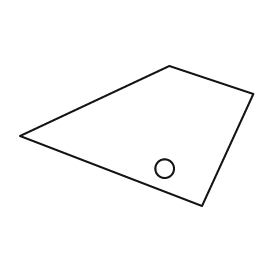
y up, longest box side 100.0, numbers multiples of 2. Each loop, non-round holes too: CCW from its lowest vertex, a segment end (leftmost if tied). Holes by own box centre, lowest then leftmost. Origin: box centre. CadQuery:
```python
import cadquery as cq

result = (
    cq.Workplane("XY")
    .moveTo(28.0, -30.0)
    .lineTo(50.0, 18.0)
    .lineTo(14.0, 30.0)
    .lineTo(-50.0, 0.0)
    .close()
    .moveTo(12.0, -14.0)
    .circle(4.0)
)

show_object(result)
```